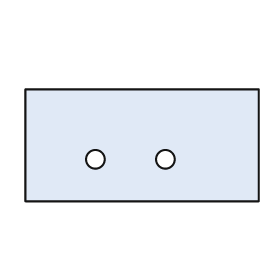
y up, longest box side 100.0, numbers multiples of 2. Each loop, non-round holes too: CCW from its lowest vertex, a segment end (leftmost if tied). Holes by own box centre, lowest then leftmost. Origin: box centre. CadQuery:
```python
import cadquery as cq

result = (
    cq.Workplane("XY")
    .moveTo(-50.0, -24.0)
    .lineTo(50.0, -24.0)
    .lineTo(50.0, 24.0)
    .lineTo(-50.0, 24.0)
    .close()
    .moveTo(-20.0, -6.0)
    .circle(4.0)
    .moveTo(10.0, -6.0)
    .circle(4.0)
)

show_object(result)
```